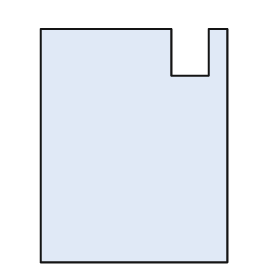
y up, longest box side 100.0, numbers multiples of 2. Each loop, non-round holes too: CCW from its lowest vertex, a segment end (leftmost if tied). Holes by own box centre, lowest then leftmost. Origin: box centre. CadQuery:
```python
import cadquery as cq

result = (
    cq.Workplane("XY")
    .moveTo(-40.0, -50.0)
    .lineTo(40.0, -50.0)
    .lineTo(40.0, 50.0)
    .lineTo(32.0, 50.0)
    .lineTo(32.0, 30.0)
    .lineTo(16.0, 30.0)
    .lineTo(16.0, 50.0)
    .lineTo(-40.0, 50.0)
    .close()
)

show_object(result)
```